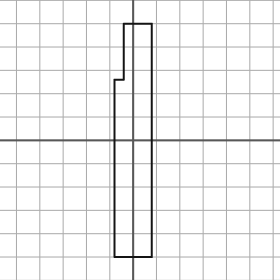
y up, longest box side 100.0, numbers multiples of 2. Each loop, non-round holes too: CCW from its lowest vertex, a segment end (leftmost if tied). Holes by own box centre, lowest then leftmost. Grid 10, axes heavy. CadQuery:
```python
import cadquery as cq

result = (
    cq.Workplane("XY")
    .moveTo(-8.0, -50.0)
    .lineTo(8.0, -50.0)
    .lineTo(8.0, 50.0)
    .lineTo(-4.0, 50.0)
    .lineTo(-4.0, 26.0)
    .lineTo(-8.0, 26.0)
    .close()
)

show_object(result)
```